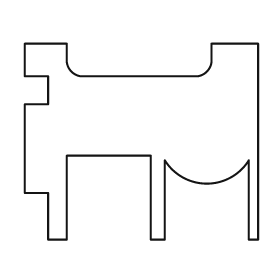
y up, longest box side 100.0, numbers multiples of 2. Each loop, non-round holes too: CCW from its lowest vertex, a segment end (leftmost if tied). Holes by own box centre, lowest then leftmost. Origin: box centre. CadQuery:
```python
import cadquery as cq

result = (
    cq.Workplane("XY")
    .moveTo(-40.0, -42.0)
    .lineTo(-32.0, -42.0)
    .lineTo(-32.0, -6.0)
    .lineTo(4.0, -6.0)
    .lineTo(4.0, -42.0)
    .lineTo(10.0, -42.0)
    .lineTo(10.0, -8.0)
    .threePointArc((28.0, -18.0), (46.0, -8.0))
    .lineTo(46.0, -42.0)
    .lineTo(50.0, -42.0)
    .lineTo(50.0, 42.0)
    .lineTo(30.0, 42.0)
    .lineTo(30.0, 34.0)
    .threePointArc((28.0, 30.0), (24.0, 28.0))
    .lineTo(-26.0, 28.0)
    .threePointArc((-30.0, 30.0), (-32.0, 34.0))
    .lineTo(-32.0, 42.0)
    .lineTo(-50.0, 42.0)
    .lineTo(-50.0, 28.0)
    .lineTo(-40.0, 28.0)
    .lineTo(-40.0, 16.0)
    .lineTo(-50.0, 16.0)
    .lineTo(-50.0, -22.0)
    .lineTo(-40.0, -22.0)
    .close()
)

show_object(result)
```